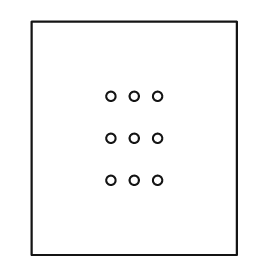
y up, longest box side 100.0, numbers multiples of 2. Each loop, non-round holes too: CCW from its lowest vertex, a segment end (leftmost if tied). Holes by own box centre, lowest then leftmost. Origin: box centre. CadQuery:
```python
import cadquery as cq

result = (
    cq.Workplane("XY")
    .moveTo(-44.0, -50.0)
    .lineTo(44.0, -50.0)
    .lineTo(44.0, 50.0)
    .lineTo(-44.0, 50.0)
    .close()
    .moveTo(-10.0, -18.0)
    .circle(2.0)
    .moveTo(0.0, -18.0)
    .circle(2.0)
    .moveTo(10.0, -18.0)
    .circle(2.0)
    .moveTo(-10.0, 0.0)
    .circle(2.0)
    .moveTo(0.0, 0.0)
    .circle(2.0)
    .moveTo(10.0, 0.0)
    .circle(2.0)
    .moveTo(-10.0, 18.0)
    .circle(2.0)
    .moveTo(0.0, 18.0)
    .circle(2.0)
    .moveTo(10.0, 18.0)
    .circle(2.0)
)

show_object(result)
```